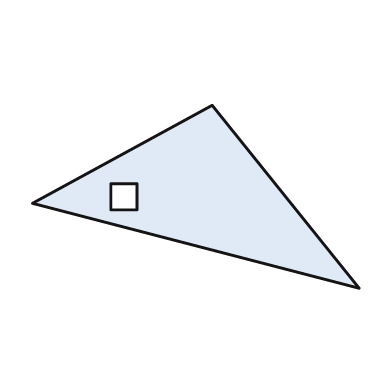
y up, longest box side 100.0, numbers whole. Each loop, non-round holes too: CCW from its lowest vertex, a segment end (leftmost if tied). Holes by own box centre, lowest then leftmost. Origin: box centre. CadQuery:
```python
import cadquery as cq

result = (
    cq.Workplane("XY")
    .moveTo(50.0, -28.0)
    .lineTo(5.0, 28.0)
    .lineTo(-50.0, -2.0)
    .close()
    .moveTo(-26.0, -4.0)
    .lineTo(-18.0, -4.0)
    .lineTo(-18.0, 4.0)
    .lineTo(-26.0, 4.0)
    .close()
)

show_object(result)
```